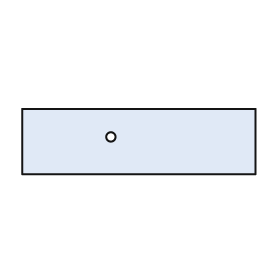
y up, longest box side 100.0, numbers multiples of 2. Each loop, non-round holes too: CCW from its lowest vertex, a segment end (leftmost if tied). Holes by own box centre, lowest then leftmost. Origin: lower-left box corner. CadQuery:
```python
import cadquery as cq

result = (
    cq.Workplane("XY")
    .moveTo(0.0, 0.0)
    .lineTo(100.0, 0.0)
    .lineTo(100.0, 28.0)
    .lineTo(0.0, 28.0)
    .close()
    .moveTo(38.0, 16.0)
    .circle(2.0)
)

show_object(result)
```